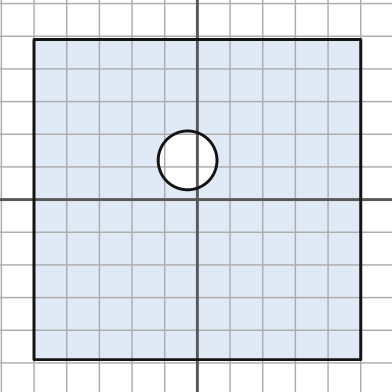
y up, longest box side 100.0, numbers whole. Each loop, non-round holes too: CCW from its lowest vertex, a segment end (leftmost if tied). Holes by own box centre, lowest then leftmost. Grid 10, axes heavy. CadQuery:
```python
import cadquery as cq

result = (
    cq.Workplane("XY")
    .moveTo(-50.0, -49.0)
    .lineTo(50.0, -49.0)
    .lineTo(50.0, 49.0)
    .lineTo(-50.0, 49.0)
    .close()
    .moveTo(-3.0, 12.0)
    .circle(9.0)
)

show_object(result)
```